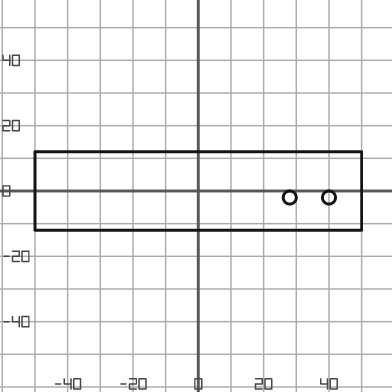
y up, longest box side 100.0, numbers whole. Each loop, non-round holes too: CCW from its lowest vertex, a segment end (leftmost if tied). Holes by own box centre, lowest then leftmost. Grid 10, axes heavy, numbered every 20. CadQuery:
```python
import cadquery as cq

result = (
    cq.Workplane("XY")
    .moveTo(-50.0, -12.0)
    .lineTo(50.0, -12.0)
    .lineTo(50.0, 12.0)
    .lineTo(-50.0, 12.0)
    .close()
    .moveTo(28.0, -2.0)
    .circle(2.0)
    .moveTo(40.0, -2.0)
    .circle(2.0)
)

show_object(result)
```